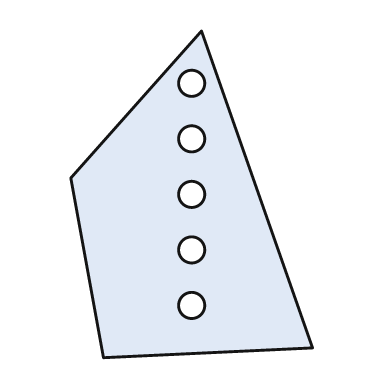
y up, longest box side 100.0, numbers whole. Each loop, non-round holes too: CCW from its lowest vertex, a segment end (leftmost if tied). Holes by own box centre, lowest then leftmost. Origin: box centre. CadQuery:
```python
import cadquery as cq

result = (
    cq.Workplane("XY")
    .moveTo(-27.0, -50.0)
    .lineTo(37.0, -47.0)
    .lineTo(3.0, 50.0)
    .lineTo(-37.0, 5.0)
    .close()
    .moveTo(0.0, -34.0)
    .circle(4.0)
    .moveTo(0.0, -17.0)
    .circle(4.0)
    .moveTo(0.0, 0.0)
    .circle(4.0)
    .moveTo(0.0, 17.0)
    .circle(4.0)
    .moveTo(0.0, 34.0)
    .circle(4.0)
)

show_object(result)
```